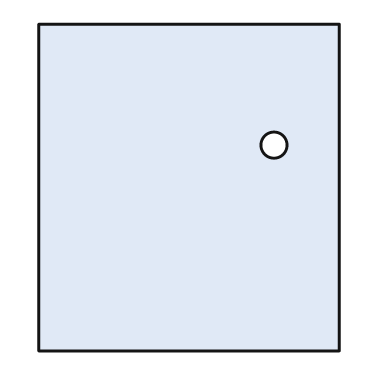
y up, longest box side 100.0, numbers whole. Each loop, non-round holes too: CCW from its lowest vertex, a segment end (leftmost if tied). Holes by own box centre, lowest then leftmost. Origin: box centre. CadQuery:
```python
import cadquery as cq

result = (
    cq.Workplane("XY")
    .moveTo(-46.0, -50.0)
    .lineTo(46.0, -50.0)
    .lineTo(46.0, 50.0)
    .lineTo(-46.0, 50.0)
    .close()
    .moveTo(26.0, 13.0)
    .circle(4.0)
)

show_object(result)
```